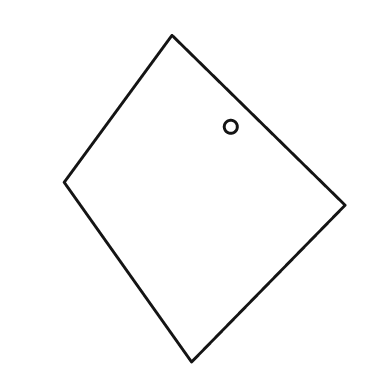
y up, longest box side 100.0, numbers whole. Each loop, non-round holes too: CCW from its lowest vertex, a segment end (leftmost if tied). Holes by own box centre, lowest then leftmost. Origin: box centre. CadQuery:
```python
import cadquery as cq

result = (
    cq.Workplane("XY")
    .moveTo(-4.0, -50.0)
    .lineTo(43.0, -2.0)
    .lineTo(-10.0, 50.0)
    .lineTo(-43.0, 5.0)
    .close()
    .moveTo(8.0, 22.0)
    .circle(2.0)
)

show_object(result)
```